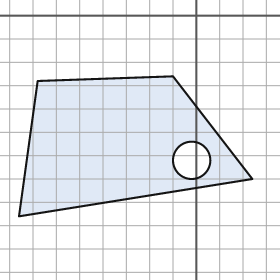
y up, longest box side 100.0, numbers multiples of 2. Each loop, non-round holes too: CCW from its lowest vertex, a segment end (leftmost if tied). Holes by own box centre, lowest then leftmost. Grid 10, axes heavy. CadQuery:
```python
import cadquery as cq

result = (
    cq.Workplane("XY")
    .moveTo(-76.0, -86.0)
    .lineTo(24.0, -70.0)
    .lineTo(-10.0, -26.0)
    .lineTo(-68.0, -28.0)
    .close()
    .moveTo(-2.0, -62.0)
    .circle(8.0)
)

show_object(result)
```